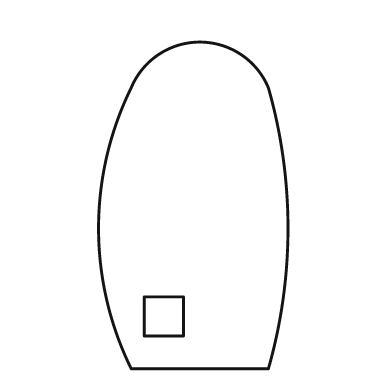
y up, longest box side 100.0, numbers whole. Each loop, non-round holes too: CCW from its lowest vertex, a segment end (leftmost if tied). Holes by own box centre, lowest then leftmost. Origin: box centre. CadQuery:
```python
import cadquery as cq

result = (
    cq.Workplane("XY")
    .moveTo(-19.0, -50.0)
    .lineTo(23.0, -50.0)
    .threePointArc((29.0, -7.0), (23.0, 36.0))
    .threePointArc((2.0, 50.0), (-19.0, 36.0))
    .threePointArc((-29.0, -7.0), (-19.0, -50.0))
    .close()
    .moveTo(-15.0, -40.0)
    .lineTo(-3.0, -40.0)
    .lineTo(-3.0, -28.0)
    .lineTo(-15.0, -28.0)
    .close()
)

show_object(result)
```